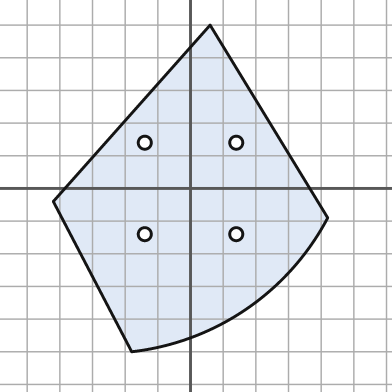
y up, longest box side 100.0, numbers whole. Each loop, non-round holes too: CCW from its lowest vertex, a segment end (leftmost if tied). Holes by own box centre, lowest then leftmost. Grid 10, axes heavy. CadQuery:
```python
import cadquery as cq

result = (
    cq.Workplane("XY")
    .moveTo(-18.0, -50.0)
    .threePointArc((17.0, -37.0), (42.0, -9.0))
    .lineTo(6.0, 50.0)
    .lineTo(-42.0, -4.0)
    .close()
    .moveTo(-14.0, -14.0)
    .circle(2.0)
    .moveTo(14.0, -14.0)
    .circle(2.0)
    .moveTo(-14.0, 14.0)
    .circle(2.0)
    .moveTo(14.0, 14.0)
    .circle(2.0)
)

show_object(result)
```